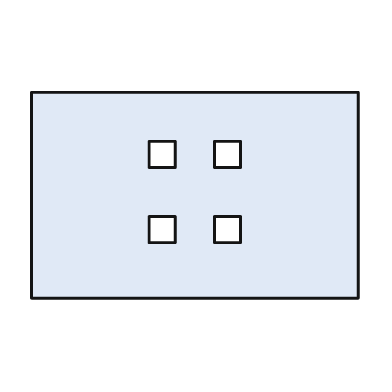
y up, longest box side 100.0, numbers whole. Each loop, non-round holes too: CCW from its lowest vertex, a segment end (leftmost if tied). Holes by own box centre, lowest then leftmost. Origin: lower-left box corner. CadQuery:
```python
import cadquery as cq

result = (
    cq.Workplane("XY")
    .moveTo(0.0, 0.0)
    .lineTo(100.0, 0.0)
    .lineTo(100.0, 63.0)
    .lineTo(0.0, 63.0)
    .close()
    .moveTo(36.0, 17.0)
    .lineTo(44.0, 17.0)
    .lineTo(44.0, 25.0)
    .lineTo(36.0, 25.0)
    .close()
    .moveTo(56.0, 17.0)
    .lineTo(64.0, 17.0)
    .lineTo(64.0, 25.0)
    .lineTo(56.0, 25.0)
    .close()
    .moveTo(36.0, 40.0)
    .lineTo(44.0, 40.0)
    .lineTo(44.0, 48.0)
    .lineTo(36.0, 48.0)
    .close()
    .moveTo(56.0, 40.0)
    .lineTo(64.0, 40.0)
    .lineTo(64.0, 48.0)
    .lineTo(56.0, 48.0)
    .close()
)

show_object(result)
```